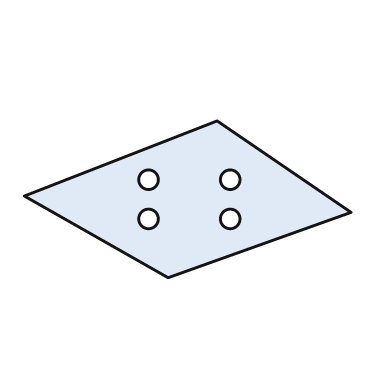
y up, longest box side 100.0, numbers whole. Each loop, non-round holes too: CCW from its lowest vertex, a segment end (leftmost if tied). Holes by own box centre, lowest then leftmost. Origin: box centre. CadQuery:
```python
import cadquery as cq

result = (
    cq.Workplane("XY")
    .moveTo(-6.0, -24.0)
    .lineTo(50.0, -4.0)
    .lineTo(9.0, 24.0)
    .lineTo(-50.0, 1.0)
    .close()
    .moveTo(-12.0, -6.0)
    .circle(3.0)
    .moveTo(13.0, -6.0)
    .circle(3.0)
    .moveTo(-12.0, 6.0)
    .circle(3.0)
    .moveTo(13.0, 6.0)
    .circle(3.0)
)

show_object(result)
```